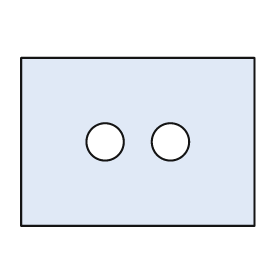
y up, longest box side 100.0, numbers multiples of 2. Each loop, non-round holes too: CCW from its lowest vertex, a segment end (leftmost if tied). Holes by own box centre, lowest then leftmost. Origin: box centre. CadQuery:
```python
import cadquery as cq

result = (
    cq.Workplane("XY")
    .moveTo(-50.0, -36.0)
    .lineTo(50.0, -36.0)
    .lineTo(50.0, 36.0)
    .lineTo(-50.0, 36.0)
    .close()
    .moveTo(-14.0, 0.0)
    .circle(8.0)
    .moveTo(14.0, 0.0)
    .circle(8.0)
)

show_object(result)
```